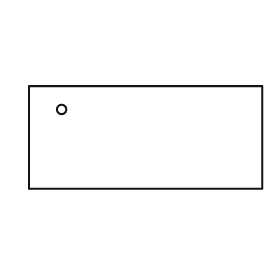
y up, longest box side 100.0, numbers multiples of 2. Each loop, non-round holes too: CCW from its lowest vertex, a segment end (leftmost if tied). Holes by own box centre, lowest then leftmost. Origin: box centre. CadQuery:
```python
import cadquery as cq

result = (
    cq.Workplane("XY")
    .moveTo(-50.0, -22.0)
    .lineTo(50.0, -22.0)
    .lineTo(50.0, 22.0)
    .lineTo(-50.0, 22.0)
    .close()
    .moveTo(-36.0, 12.0)
    .circle(2.0)
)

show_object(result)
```